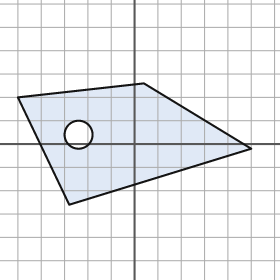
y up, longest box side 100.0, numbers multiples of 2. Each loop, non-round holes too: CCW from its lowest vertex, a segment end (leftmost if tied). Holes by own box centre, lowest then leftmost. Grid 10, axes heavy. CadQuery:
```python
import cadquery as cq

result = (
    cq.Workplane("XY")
    .moveTo(-28.0, -26.0)
    .lineTo(50.0, -2.0)
    .lineTo(4.0, 26.0)
    .lineTo(-50.0, 20.0)
    .close()
    .moveTo(-24.0, 4.0)
    .circle(6.0)
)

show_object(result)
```